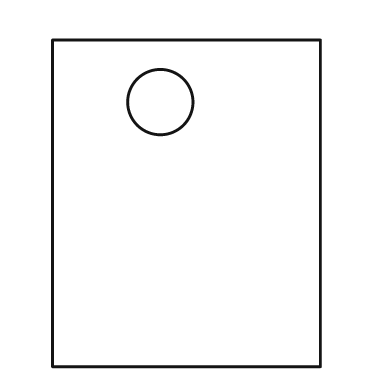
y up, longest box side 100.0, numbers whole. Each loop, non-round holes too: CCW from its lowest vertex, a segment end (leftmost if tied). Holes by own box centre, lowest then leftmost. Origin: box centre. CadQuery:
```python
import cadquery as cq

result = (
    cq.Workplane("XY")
    .moveTo(-41.0, -50.0)
    .lineTo(41.0, -50.0)
    .lineTo(41.0, 50.0)
    .lineTo(-41.0, 50.0)
    .close()
    .moveTo(-8.0, 31.0)
    .circle(10.0)
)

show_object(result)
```